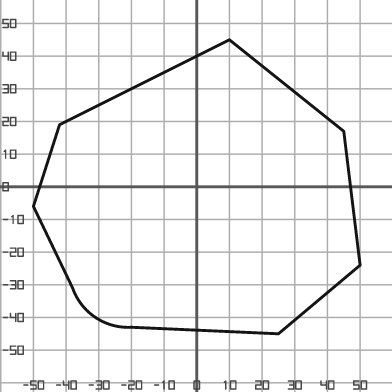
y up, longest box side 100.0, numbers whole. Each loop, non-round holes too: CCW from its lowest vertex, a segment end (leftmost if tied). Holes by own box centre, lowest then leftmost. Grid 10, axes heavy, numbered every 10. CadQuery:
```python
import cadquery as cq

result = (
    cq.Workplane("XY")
    .moveTo(25.0, -45.0)
    .lineTo(50.0, -24.0)
    .lineTo(45.0, 17.0)
    .lineTo(10.0, 45.0)
    .lineTo(-42.0, 19.0)
    .lineTo(-50.0, -6.0)
    .lineTo(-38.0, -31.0)
    .threePointArc((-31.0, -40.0), (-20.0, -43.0))
    .close()
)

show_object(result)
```